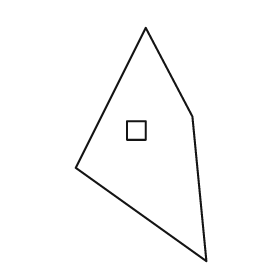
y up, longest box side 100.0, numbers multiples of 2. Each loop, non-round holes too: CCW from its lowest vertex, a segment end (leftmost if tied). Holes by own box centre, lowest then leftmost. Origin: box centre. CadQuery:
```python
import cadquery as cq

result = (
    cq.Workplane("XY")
    .moveTo(28.0, -50.0)
    .lineTo(22.0, 12.0)
    .lineTo(2.0, 50.0)
    .lineTo(-28.0, -10.0)
    .close()
    .moveTo(-6.0, 2.0)
    .lineTo(2.0, 2.0)
    .lineTo(2.0, 10.0)
    .lineTo(-6.0, 10.0)
    .close()
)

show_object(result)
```